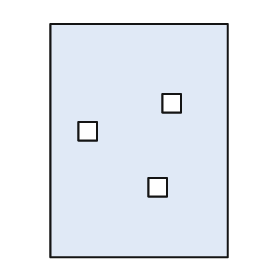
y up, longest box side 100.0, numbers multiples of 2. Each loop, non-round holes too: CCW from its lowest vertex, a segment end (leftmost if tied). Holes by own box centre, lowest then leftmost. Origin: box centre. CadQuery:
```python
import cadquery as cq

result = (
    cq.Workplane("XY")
    .moveTo(-38.0, -50.0)
    .lineTo(38.0, -50.0)
    .lineTo(38.0, 50.0)
    .lineTo(-38.0, 50.0)
    .close()
    .moveTo(4.0, -24.0)
    .lineTo(12.0, -24.0)
    .lineTo(12.0, -16.0)
    .lineTo(4.0, -16.0)
    .close()
    .moveTo(-26.0, 0.0)
    .lineTo(-18.0, 0.0)
    .lineTo(-18.0, 8.0)
    .lineTo(-26.0, 8.0)
    .close()
    .moveTo(10.0, 12.0)
    .lineTo(18.0, 12.0)
    .lineTo(18.0, 20.0)
    .lineTo(10.0, 20.0)
    .close()
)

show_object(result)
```